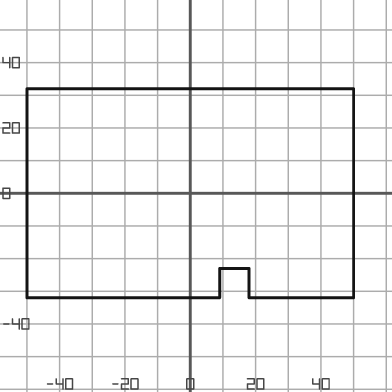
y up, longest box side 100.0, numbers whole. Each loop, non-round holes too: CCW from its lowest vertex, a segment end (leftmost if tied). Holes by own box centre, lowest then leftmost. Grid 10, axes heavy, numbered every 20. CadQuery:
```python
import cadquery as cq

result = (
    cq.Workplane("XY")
    .moveTo(-50.0, -32.0)
    .lineTo(9.0, -32.0)
    .lineTo(9.0, -23.0)
    .lineTo(18.0, -23.0)
    .lineTo(18.0, -32.0)
    .lineTo(50.0, -32.0)
    .lineTo(50.0, 32.0)
    .lineTo(-50.0, 32.0)
    .close()
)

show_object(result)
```